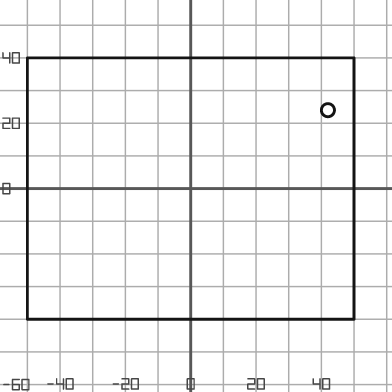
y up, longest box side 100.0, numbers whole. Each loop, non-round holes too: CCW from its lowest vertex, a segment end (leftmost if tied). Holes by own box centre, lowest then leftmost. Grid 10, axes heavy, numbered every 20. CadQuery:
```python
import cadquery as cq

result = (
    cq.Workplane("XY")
    .moveTo(-50.0, -40.0)
    .lineTo(50.0, -40.0)
    .lineTo(50.0, 40.0)
    .lineTo(-50.0, 40.0)
    .close()
    .moveTo(42.0, 24.0)
    .circle(2.0)
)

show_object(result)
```